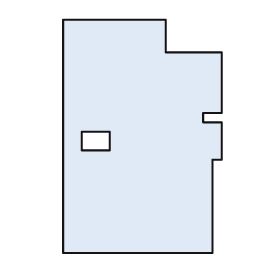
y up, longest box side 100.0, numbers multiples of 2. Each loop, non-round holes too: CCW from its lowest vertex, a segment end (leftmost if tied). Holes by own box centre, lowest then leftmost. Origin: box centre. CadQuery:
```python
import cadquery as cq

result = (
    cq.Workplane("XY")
    .moveTo(-34.0, -50.0)
    .lineTo(30.0, -50.0)
    .lineTo(30.0, -10.0)
    .lineTo(34.0, -10.0)
    .lineTo(34.0, 6.0)
    .lineTo(26.0, 6.0)
    .lineTo(26.0, 10.0)
    .lineTo(34.0, 10.0)
    .lineTo(34.0, 36.0)
    .lineTo(10.0, 36.0)
    .lineTo(10.0, 50.0)
    .lineTo(-34.0, 50.0)
    .close()
    .moveTo(-26.0, -6.0)
    .lineTo(-14.0, -6.0)
    .lineTo(-14.0, 2.0)
    .lineTo(-26.0, 2.0)
    .close()
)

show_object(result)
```